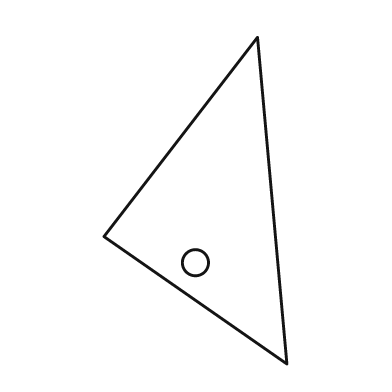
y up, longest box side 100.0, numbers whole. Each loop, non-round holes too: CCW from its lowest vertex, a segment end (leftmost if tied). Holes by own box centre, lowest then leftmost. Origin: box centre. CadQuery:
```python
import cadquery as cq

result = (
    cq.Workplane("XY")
    .moveTo(28.0, -50.0)
    .lineTo(19.0, 50.0)
    .lineTo(-28.0, -11.0)
    .close()
    .moveTo(0.0, -19.0)
    .circle(4.0)
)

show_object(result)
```